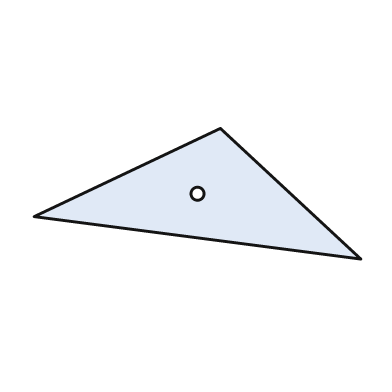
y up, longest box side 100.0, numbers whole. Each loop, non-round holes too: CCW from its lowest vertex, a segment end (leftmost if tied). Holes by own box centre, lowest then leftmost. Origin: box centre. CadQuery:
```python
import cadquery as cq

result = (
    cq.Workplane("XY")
    .moveTo(50.0, -20.0)
    .lineTo(7.0, 20.0)
    .lineTo(-50.0, -7.0)
    .close()
    .moveTo(0.0, 0.0)
    .circle(2.0)
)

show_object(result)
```